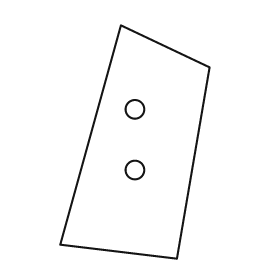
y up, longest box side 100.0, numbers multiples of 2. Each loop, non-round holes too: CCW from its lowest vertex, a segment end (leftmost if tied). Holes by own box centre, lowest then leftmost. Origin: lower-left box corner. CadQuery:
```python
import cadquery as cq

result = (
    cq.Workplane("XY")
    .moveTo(50.0, 0.0)
    .lineTo(64.0, 82.0)
    .lineTo(26.0, 100.0)
    .lineTo(0.0, 6.0)
    .close()
    .moveTo(32.0, 38.0)
    .circle(4.0)
    .moveTo(32.0, 64.0)
    .circle(4.0)
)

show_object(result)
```